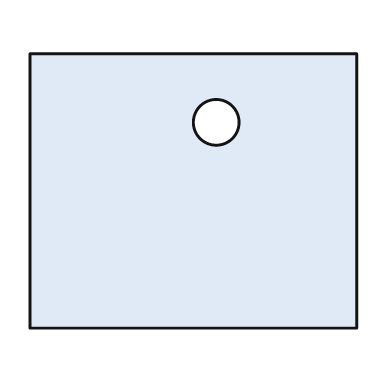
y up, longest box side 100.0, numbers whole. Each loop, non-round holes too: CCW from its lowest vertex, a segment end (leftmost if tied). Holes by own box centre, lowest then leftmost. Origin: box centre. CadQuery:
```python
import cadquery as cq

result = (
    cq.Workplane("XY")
    .moveTo(-50.0, -42.0)
    .lineTo(50.0, -42.0)
    .lineTo(50.0, 42.0)
    .lineTo(-50.0, 42.0)
    .close()
    .moveTo(7.0, 21.0)
    .circle(7.0)
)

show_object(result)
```